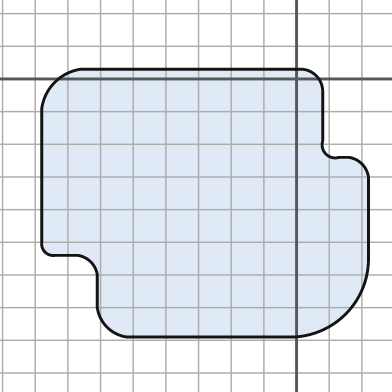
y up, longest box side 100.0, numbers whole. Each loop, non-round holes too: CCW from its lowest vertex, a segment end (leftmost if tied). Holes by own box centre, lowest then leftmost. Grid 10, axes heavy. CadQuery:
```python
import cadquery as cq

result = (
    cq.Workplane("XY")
    .moveTo(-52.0, -79.0)
    .lineTo(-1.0, -79.0)
    .threePointArc((15.0, -72.0), (22.0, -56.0))
    .lineTo(22.0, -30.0)
    .threePointArc((20.0, -26.0), (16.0, -24.0))
    .lineTo(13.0, -24.0)
    .threePointArc((9.0, -23.0), (8.0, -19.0))
    .lineTo(8.0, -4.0)
    .threePointArc((6.0, 1.0), (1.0, 3.0))
    .lineTo(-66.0, 3.0)
    .threePointArc((-74.0, -1.0), (-78.0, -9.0))
    .lineTo(-78.0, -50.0)
    .threePointArc((-77.0, -53.0), (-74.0, -54.0))
    .lineTo(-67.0, -54.0)
    .threePointArc((-63.0, -56.0), (-61.0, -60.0))
    .lineTo(-61.0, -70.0)
    .threePointArc((-58.0, -76.0), (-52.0, -79.0))
    .close()
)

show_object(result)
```